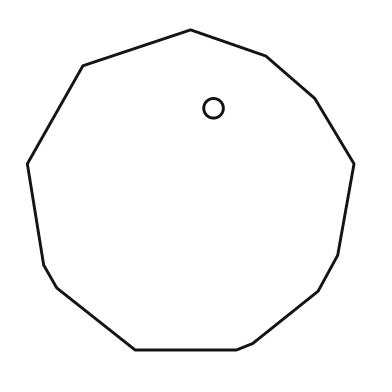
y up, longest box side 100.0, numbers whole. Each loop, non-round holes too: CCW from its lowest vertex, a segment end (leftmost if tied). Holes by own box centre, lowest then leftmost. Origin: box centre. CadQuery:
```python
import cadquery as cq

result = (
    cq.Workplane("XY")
    .moveTo(-17.0, -49.0)
    .lineTo(14.0, -49.0)
    .lineTo(19.0, -47.0)
    .lineTo(39.0, -31.0)
    .lineTo(45.0, -20.0)
    .lineTo(50.0, 8.0)
    .lineTo(38.0, 28.0)
    .lineTo(23.0, 41.0)
    .lineTo(0.0, 49.0)
    .lineTo(-33.0, 38.0)
    .lineTo(-50.0, 8.0)
    .lineTo(-45.0, -23.0)
    .lineTo(-41.0, -30.0)
    .close()
    .moveTo(7.0, 25.0)
    .circle(3.0)
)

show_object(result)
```